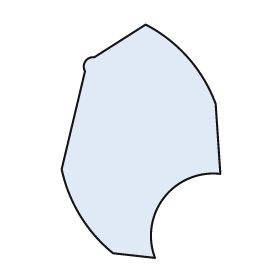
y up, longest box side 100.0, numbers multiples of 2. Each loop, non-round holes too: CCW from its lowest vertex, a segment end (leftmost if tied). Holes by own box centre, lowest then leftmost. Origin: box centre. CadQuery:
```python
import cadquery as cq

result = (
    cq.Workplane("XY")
    .moveTo(6.0, -50.0)
    .threePointArc((10.0, -24.0), (34.0, -14.0))
    .lineTo(32.0, 16.0)
    .threePointArc((20.0, 36.0), (2.0, 50.0))
    .lineTo(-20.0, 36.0)
    .threePointArc((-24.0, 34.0), (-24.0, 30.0))
    .lineTo(-34.0, -12.0)
    .threePointArc((-26.0, -32.0), (-12.0, -48.0))
    .close()
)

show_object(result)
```